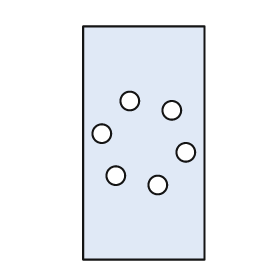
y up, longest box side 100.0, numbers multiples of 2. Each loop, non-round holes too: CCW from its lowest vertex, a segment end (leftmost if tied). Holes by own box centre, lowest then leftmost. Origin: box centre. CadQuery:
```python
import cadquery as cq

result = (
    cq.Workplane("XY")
    .moveTo(-26.0, -50.0)
    .lineTo(26.0, -50.0)
    .lineTo(26.0, 50.0)
    .lineTo(-26.0, 50.0)
    .close()
    .moveTo(6.0, -18.0)
    .circle(4.0)
    .moveTo(-12.0, -14.0)
    .circle(4.0)
    .moveTo(18.0, -4.0)
    .circle(4.0)
    .moveTo(-18.0, 4.0)
    .circle(4.0)
    .moveTo(12.0, 14.0)
    .circle(4.0)
    .moveTo(-6.0, 18.0)
    .circle(4.0)
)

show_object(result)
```